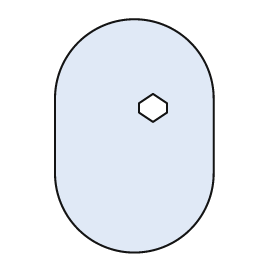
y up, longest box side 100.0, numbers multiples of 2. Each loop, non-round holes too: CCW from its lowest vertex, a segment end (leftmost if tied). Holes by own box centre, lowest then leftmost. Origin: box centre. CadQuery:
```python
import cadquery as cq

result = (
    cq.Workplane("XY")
    .moveTo(-34.0, -16.0)
    .threePointArc((0.0, -50.0), (34.0, -16.0))
    .lineTo(34.0, 16.0)
    .threePointArc((0.0, 50.0), (-34.0, 16.0))
    .close()
    .moveTo(8.0, 6.0)
    .lineTo(14.0, 10.0)
    .lineTo(14.0, 14.0)
    .lineTo(8.0, 18.0)
    .lineTo(2.0, 14.0)
    .lineTo(2.0, 10.0)
    .close()
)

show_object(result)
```